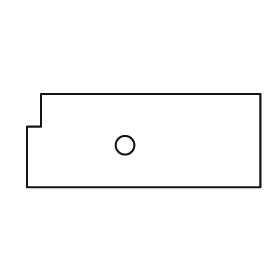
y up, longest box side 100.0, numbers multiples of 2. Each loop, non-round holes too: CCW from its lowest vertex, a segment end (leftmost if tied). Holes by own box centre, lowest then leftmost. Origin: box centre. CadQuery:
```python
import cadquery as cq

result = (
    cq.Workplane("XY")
    .moveTo(-50.0, -20.0)
    .lineTo(50.0, -20.0)
    .lineTo(50.0, 20.0)
    .lineTo(-44.0, 20.0)
    .lineTo(-44.0, 6.0)
    .lineTo(-50.0, 6.0)
    .close()
    .moveTo(-8.0, -2.0)
    .circle(4.0)
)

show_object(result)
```